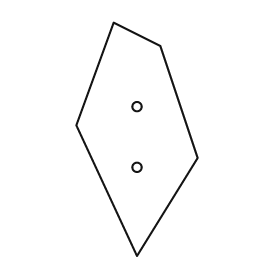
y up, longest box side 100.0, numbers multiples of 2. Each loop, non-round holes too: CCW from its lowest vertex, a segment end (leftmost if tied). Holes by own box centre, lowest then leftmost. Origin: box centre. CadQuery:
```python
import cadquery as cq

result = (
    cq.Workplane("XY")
    .moveTo(0.0, -50.0)
    .lineTo(26.0, -8.0)
    .lineTo(10.0, 40.0)
    .lineTo(-10.0, 50.0)
    .lineTo(-26.0, 6.0)
    .close()
    .moveTo(0.0, -12.0)
    .circle(2.0)
    .moveTo(0.0, 14.0)
    .circle(2.0)
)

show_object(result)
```